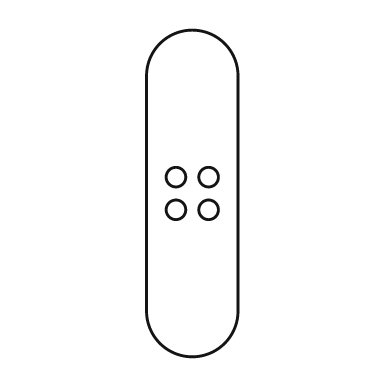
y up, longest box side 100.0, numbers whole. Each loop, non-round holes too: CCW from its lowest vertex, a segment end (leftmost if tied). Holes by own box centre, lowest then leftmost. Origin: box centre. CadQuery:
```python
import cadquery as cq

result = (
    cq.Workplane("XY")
    .moveTo(-14.0, -36.0)
    .threePointArc((0.0, -50.0), (14.0, -36.0))
    .lineTo(14.0, 36.0)
    .threePointArc((0.0, 50.0), (-14.0, 36.0))
    .close()
    .moveTo(-5.0, -5.0)
    .circle(3.0)
    .moveTo(5.0, -5.0)
    .circle(3.0)
    .moveTo(-5.0, 5.0)
    .circle(3.0)
    .moveTo(5.0, 5.0)
    .circle(3.0)
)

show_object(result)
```